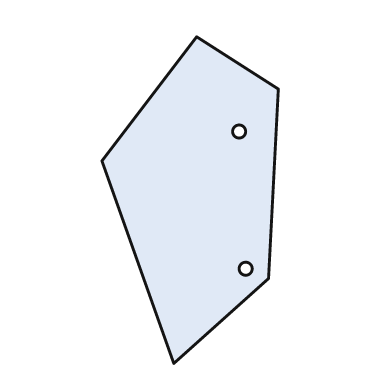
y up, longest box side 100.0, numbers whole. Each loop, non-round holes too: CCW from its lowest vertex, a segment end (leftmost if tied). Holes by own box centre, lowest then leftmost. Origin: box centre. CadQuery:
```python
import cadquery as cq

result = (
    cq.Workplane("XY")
    .moveTo(-5.0, -50.0)
    .lineTo(24.0, -24.0)
    .lineTo(27.0, 34.0)
    .lineTo(2.0, 50.0)
    .lineTo(-27.0, 12.0)
    .close()
    .moveTo(17.0, -21.0)
    .circle(2.0)
    .moveTo(15.0, 21.0)
    .circle(2.0)
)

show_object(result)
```